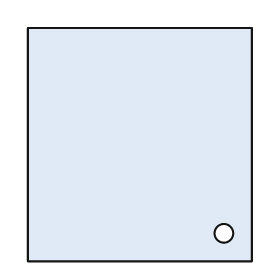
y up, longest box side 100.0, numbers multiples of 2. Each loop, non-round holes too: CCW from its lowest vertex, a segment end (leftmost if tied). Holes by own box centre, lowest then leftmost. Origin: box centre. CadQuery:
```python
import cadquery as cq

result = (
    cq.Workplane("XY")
    .moveTo(-48.0, -50.0)
    .lineTo(48.0, -50.0)
    .lineTo(48.0, 50.0)
    .lineTo(-48.0, 50.0)
    .close()
    .moveTo(36.0, -38.0)
    .circle(4.0)
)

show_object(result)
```